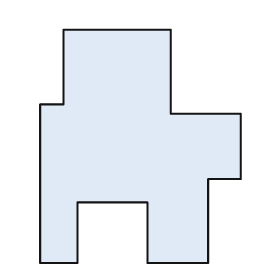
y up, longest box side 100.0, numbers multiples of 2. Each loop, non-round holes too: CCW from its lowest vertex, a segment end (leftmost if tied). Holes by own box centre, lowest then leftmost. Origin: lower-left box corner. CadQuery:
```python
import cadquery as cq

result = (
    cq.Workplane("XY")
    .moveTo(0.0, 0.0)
    .lineTo(16.0, 0.0)
    .lineTo(16.0, 26.0)
    .lineTo(46.0, 26.0)
    .lineTo(46.0, 0.0)
    .lineTo(72.0, 0.0)
    .lineTo(72.0, 36.0)
    .lineTo(86.0, 36.0)
    .lineTo(86.0, 64.0)
    .lineTo(56.0, 64.0)
    .lineTo(56.0, 100.0)
    .lineTo(10.0, 100.0)
    .lineTo(10.0, 68.0)
    .lineTo(0.0, 68.0)
    .close()
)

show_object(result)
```